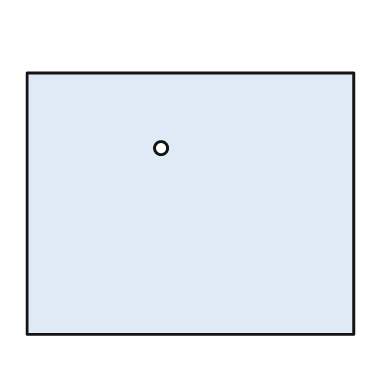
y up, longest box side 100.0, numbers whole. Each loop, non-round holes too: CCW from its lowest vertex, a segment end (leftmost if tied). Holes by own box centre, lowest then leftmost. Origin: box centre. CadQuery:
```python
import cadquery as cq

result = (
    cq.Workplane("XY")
    .moveTo(-50.0, -40.0)
    .lineTo(50.0, -40.0)
    .lineTo(50.0, 40.0)
    .lineTo(-50.0, 40.0)
    .close()
    .moveTo(-9.0, 17.0)
    .circle(2.0)
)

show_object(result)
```